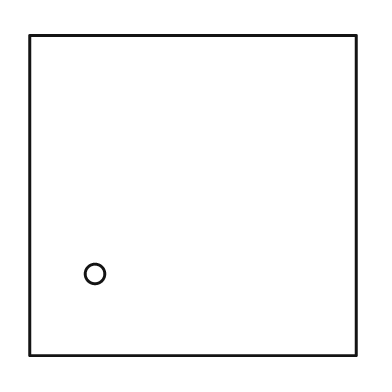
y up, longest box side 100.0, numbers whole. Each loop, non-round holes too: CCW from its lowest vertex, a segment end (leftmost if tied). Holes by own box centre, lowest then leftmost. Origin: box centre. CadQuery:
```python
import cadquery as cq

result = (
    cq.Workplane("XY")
    .moveTo(-50.0, -49.0)
    .lineTo(50.0, -49.0)
    .lineTo(50.0, 49.0)
    .lineTo(-50.0, 49.0)
    .close()
    .moveTo(-30.0, -24.0)
    .circle(3.0)
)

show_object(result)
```